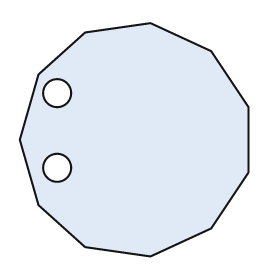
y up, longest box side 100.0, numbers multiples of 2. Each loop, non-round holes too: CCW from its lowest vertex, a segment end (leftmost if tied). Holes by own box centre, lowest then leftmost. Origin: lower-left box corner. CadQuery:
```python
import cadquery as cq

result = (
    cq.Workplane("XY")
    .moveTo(56.0, 0.0)
    .lineTo(82.0, 12.0)
    .lineTo(98.0, 36.0)
    .lineTo(98.0, 64.0)
    .lineTo(82.0, 88.0)
    .lineTo(56.0, 100.0)
    .lineTo(28.0, 96.0)
    .lineTo(8.0, 78.0)
    .lineTo(0.0, 50.0)
    .lineTo(8.0, 22.0)
    .lineTo(28.0, 4.0)
    .close()
    .moveTo(16.0, 38.0)
    .circle(6.0)
    .moveTo(16.0, 70.0)
    .circle(6.0)
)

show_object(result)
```